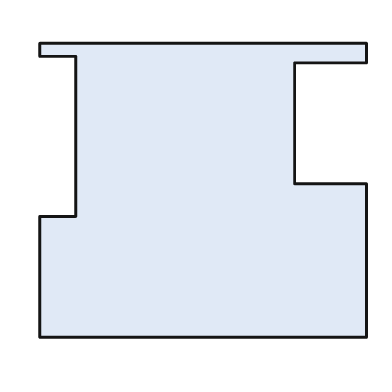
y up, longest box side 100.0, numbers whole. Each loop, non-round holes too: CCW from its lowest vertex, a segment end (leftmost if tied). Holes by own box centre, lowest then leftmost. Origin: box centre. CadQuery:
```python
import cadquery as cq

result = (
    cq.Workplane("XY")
    .moveTo(-50.0, -45.0)
    .lineTo(50.0, -45.0)
    .lineTo(50.0, 2.0)
    .lineTo(28.0, 2.0)
    .lineTo(28.0, 39.0)
    .lineTo(50.0, 39.0)
    .lineTo(50.0, 45.0)
    .lineTo(-50.0, 45.0)
    .lineTo(-50.0, 41.0)
    .lineTo(-39.0, 41.0)
    .lineTo(-39.0, -8.0)
    .lineTo(-50.0, -8.0)
    .close()
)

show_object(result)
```